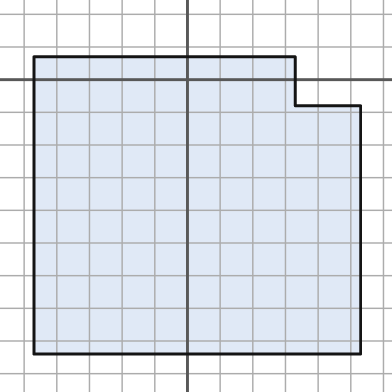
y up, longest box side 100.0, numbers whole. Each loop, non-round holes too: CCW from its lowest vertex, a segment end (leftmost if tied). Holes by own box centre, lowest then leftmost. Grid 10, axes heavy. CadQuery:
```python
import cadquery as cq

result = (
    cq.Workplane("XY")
    .moveTo(-47.0, -84.0)
    .lineTo(53.0, -84.0)
    .lineTo(53.0, -8.0)
    .lineTo(33.0, -8.0)
    .lineTo(33.0, 7.0)
    .lineTo(-47.0, 7.0)
    .close()
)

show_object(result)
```